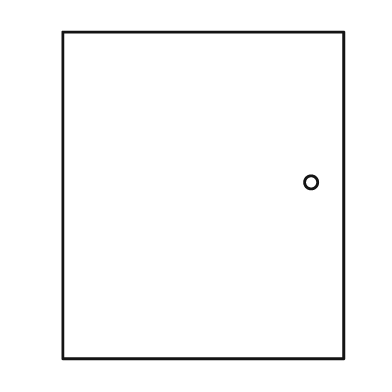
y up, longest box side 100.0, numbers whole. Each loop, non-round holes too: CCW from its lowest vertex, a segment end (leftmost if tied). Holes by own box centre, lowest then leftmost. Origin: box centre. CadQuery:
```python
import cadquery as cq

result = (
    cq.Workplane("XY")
    .moveTo(-43.0, -50.0)
    .lineTo(43.0, -50.0)
    .lineTo(43.0, 50.0)
    .lineTo(-43.0, 50.0)
    .close()
    .moveTo(33.0, 4.0)
    .circle(2.0)
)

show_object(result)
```